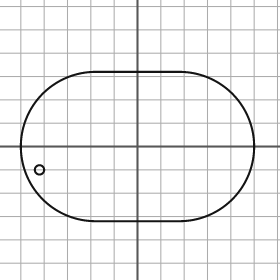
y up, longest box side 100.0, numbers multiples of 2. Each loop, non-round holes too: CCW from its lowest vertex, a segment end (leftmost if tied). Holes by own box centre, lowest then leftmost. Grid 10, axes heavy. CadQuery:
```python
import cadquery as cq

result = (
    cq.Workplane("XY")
    .moveTo(-18.0, -32.0)
    .lineTo(18.0, -32.0)
    .threePointArc((50.0, 0.0), (18.0, 32.0))
    .lineTo(-18.0, 32.0)
    .threePointArc((-50.0, 0.0), (-18.0, -32.0))
    .close()
    .moveTo(-42.0, -10.0)
    .circle(2.0)
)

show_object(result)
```